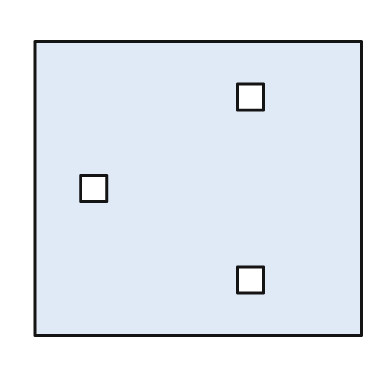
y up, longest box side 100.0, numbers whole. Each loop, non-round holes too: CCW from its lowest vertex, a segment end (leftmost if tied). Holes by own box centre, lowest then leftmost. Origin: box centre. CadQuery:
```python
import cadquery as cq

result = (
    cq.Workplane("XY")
    .moveTo(-50.0, -45.0)
    .lineTo(50.0, -45.0)
    .lineTo(50.0, 45.0)
    .lineTo(-50.0, 45.0)
    .close()
    .moveTo(12.0, -32.0)
    .lineTo(20.0, -32.0)
    .lineTo(20.0, -24.0)
    .lineTo(12.0, -24.0)
    .close()
    .moveTo(-36.0, -4.0)
    .lineTo(-28.0, -4.0)
    .lineTo(-28.0, 4.0)
    .lineTo(-36.0, 4.0)
    .close()
    .moveTo(12.0, 24.0)
    .lineTo(20.0, 24.0)
    .lineTo(20.0, 32.0)
    .lineTo(12.0, 32.0)
    .close()
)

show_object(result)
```